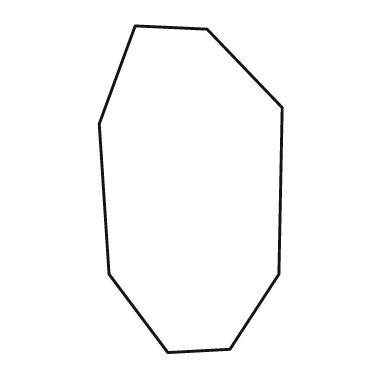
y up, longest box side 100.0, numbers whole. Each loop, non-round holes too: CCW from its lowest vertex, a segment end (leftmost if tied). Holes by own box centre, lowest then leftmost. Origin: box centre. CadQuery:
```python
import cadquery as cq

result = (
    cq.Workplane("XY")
    .moveTo(-7.0, -50.0)
    .lineTo(12.0, -49.0)
    .lineTo(27.0, -26.0)
    .lineTo(28.0, 25.0)
    .lineTo(5.0, 49.0)
    .lineTo(-17.0, 50.0)
    .lineTo(-28.0, 20.0)
    .lineTo(-25.0, -26.0)
    .close()
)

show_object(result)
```